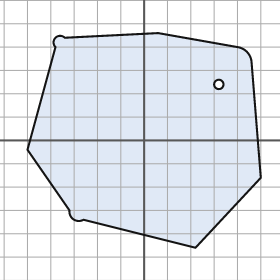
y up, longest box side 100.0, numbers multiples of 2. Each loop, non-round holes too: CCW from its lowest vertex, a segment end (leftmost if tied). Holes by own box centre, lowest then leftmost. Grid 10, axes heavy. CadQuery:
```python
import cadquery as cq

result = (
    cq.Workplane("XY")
    .moveTo(22.0, -46.0)
    .lineTo(50.0, -16.0)
    .lineTo(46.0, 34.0)
    .threePointArc((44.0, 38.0), (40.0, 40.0))
    .lineTo(6.0, 46.0)
    .lineTo(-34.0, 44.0)
    .threePointArc((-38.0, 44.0), (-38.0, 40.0))
    .lineTo(-50.0, -4.0)
    .lineTo(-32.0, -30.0)
    .threePointArc((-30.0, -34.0), (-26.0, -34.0))
    .close()
    .moveTo(32.0, 24.0)
    .circle(2.0)
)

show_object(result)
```